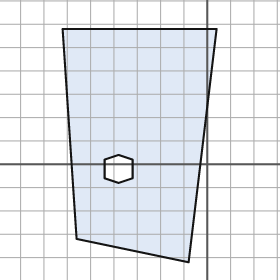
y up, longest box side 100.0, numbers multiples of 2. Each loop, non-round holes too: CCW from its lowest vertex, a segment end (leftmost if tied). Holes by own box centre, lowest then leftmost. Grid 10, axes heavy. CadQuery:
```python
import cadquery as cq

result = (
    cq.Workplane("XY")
    .moveTo(-8.0, -42.0)
    .lineTo(4.0, 58.0)
    .lineTo(-62.0, 58.0)
    .lineTo(-56.0, -32.0)
    .close()
    .moveTo(-38.0, -8.0)
    .lineTo(-32.0, -6.0)
    .lineTo(-32.0, 2.0)
    .lineTo(-38.0, 4.0)
    .lineTo(-44.0, 2.0)
    .lineTo(-44.0, -6.0)
    .close()
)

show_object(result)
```